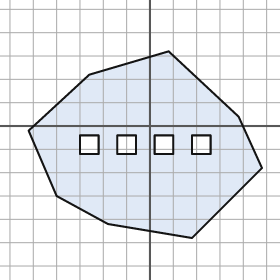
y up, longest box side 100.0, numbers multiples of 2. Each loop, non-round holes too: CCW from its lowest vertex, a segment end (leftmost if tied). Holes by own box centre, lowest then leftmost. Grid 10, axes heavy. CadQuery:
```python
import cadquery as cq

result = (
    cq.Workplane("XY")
    .moveTo(18.0, -48.0)
    .lineTo(48.0, -18.0)
    .lineTo(38.0, 4.0)
    .lineTo(8.0, 32.0)
    .lineTo(-26.0, 22.0)
    .lineTo(-52.0, -2.0)
    .lineTo(-40.0, -30.0)
    .lineTo(-18.0, -42.0)
    .close()
    .moveTo(-30.0, -12.0)
    .lineTo(-22.0, -12.0)
    .lineTo(-22.0, -4.0)
    .lineTo(-30.0, -4.0)
    .close()
    .moveTo(-14.0, -12.0)
    .lineTo(-6.0, -12.0)
    .lineTo(-6.0, -4.0)
    .lineTo(-14.0, -4.0)
    .close()
    .moveTo(2.0, -12.0)
    .lineTo(10.0, -12.0)
    .lineTo(10.0, -4.0)
    .lineTo(2.0, -4.0)
    .close()
    .moveTo(18.0, -12.0)
    .lineTo(26.0, -12.0)
    .lineTo(26.0, -4.0)
    .lineTo(18.0, -4.0)
    .close()
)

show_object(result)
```